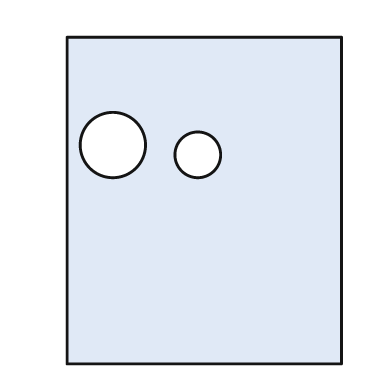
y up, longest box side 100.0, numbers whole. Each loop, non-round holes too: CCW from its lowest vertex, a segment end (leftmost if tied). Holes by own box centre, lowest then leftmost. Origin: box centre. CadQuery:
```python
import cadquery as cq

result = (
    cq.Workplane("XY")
    .moveTo(-42.0, -50.0)
    .lineTo(42.0, -50.0)
    .lineTo(42.0, 50.0)
    .lineTo(-42.0, 50.0)
    .close()
    .moveTo(-2.0, 14.0)
    .circle(7.0)
    .moveTo(-28.0, 17.0)
    .circle(10.0)
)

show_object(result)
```